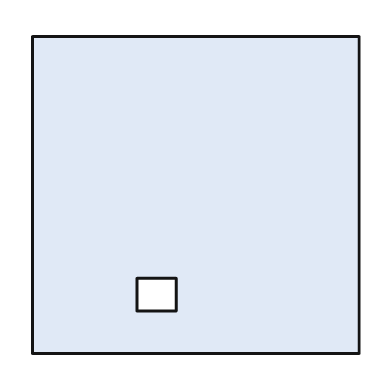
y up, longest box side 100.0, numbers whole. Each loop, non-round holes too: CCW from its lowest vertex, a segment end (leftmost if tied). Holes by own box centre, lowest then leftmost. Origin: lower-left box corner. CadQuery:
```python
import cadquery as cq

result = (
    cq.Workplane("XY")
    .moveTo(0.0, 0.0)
    .lineTo(100.0, 0.0)
    .lineTo(100.0, 97.0)
    .lineTo(0.0, 97.0)
    .close()
    .moveTo(32.0, 13.0)
    .lineTo(44.0, 13.0)
    .lineTo(44.0, 23.0)
    .lineTo(32.0, 23.0)
    .close()
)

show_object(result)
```